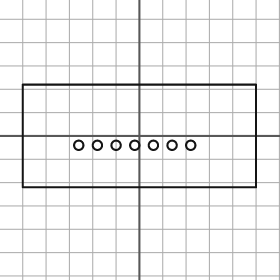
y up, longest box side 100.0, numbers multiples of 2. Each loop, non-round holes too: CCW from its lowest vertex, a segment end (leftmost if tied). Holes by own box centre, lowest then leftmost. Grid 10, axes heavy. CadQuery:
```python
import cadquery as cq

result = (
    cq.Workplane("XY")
    .moveTo(-50.0, -22.0)
    .lineTo(50.0, -22.0)
    .lineTo(50.0, 22.0)
    .lineTo(-50.0, 22.0)
    .close()
    .moveTo(-26.0, -4.0)
    .circle(2.0)
    .moveTo(-18.0, -4.0)
    .circle(2.0)
    .moveTo(-10.0, -4.0)
    .circle(2.0)
    .moveTo(-2.0, -4.0)
    .circle(2.0)
    .moveTo(6.0, -4.0)
    .circle(2.0)
    .moveTo(14.0, -4.0)
    .circle(2.0)
    .moveTo(22.0, -4.0)
    .circle(2.0)
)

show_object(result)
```